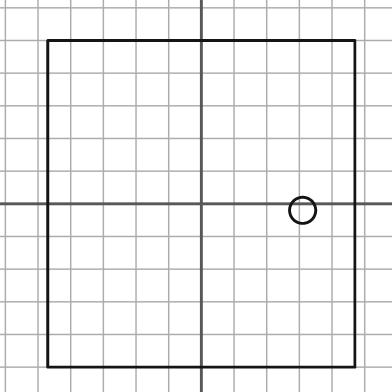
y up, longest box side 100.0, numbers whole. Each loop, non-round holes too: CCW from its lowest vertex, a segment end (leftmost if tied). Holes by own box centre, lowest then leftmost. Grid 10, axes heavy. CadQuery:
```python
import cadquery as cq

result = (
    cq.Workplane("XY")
    .moveTo(-47.0, -50.0)
    .lineTo(47.0, -50.0)
    .lineTo(47.0, 50.0)
    .lineTo(-47.0, 50.0)
    .close()
    .moveTo(31.0, -2.0)
    .circle(4.0)
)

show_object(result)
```